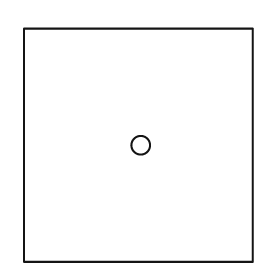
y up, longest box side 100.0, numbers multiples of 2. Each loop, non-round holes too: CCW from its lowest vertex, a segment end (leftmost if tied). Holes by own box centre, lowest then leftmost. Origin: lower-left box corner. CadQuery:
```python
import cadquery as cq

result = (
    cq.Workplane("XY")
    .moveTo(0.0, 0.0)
    .lineTo(98.0, 0.0)
    .lineTo(98.0, 100.0)
    .lineTo(0.0, 100.0)
    .close()
    .moveTo(50.0, 50.0)
    .circle(4.0)
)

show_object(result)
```